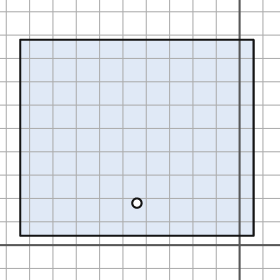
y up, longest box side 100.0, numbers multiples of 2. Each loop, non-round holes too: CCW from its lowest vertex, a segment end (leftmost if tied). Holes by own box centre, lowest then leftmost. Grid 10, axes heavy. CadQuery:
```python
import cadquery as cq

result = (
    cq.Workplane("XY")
    .moveTo(-94.0, 4.0)
    .lineTo(6.0, 4.0)
    .lineTo(6.0, 88.0)
    .lineTo(-94.0, 88.0)
    .close()
    .moveTo(-44.0, 18.0)
    .circle(2.0)
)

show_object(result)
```